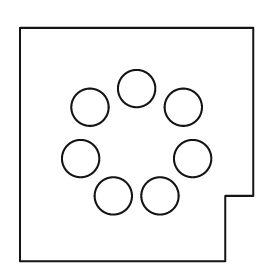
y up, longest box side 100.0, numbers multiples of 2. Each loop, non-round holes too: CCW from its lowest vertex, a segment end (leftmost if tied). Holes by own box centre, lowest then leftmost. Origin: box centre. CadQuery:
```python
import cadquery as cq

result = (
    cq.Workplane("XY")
    .moveTo(-50.0, -50.0)
    .lineTo(38.0, -50.0)
    .lineTo(38.0, -22.0)
    .lineTo(50.0, -22.0)
    .lineTo(50.0, 50.0)
    .lineTo(-50.0, 50.0)
    .close()
    .moveTo(-10.0, -22.0)
    .circle(8.0)
    .moveTo(10.0, -22.0)
    .circle(8.0)
    .moveTo(-24.0, -6.0)
    .circle(8.0)
    .moveTo(24.0, -6.0)
    .circle(8.0)
    .moveTo(-20.0, 16.0)
    .circle(8.0)
    .moveTo(20.0, 16.0)
    .circle(8.0)
    .moveTo(0.0, 24.0)
    .circle(8.0)
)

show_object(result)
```